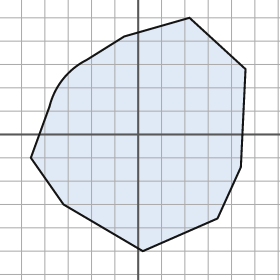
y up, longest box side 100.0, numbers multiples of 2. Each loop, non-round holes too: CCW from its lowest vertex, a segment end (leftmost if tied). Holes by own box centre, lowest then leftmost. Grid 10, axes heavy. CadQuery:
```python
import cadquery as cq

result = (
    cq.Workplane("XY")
    .moveTo(2.0, -50.0)
    .lineTo(34.0, -36.0)
    .lineTo(44.0, -14.0)
    .lineTo(46.0, 28.0)
    .lineTo(22.0, 50.0)
    .lineTo(-6.0, 42.0)
    .lineTo(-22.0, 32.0)
    .threePointArc((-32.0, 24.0), (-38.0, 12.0))
    .lineTo(-46.0, -10.0)
    .lineTo(-32.0, -30.0)
    .close()
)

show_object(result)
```